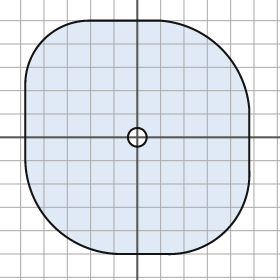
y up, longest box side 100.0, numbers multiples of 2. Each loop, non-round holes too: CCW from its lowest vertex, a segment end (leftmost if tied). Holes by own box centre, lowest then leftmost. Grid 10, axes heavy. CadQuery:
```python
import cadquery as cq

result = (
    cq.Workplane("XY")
    .moveTo(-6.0, -50.0)
    .lineTo(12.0, -50.0)
    .threePointArc((38.0, -40.0), (48.0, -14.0))
    .lineTo(48.0, 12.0)
    .threePointArc((36.0, 38.0), (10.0, 50.0))
    .lineTo(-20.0, 50.0)
    .threePointArc((-40.0, 42.0), (-48.0, 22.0))
    .lineTo(-48.0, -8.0)
    .threePointArc((-36.0, -38.0), (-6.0, -50.0))
    .close()
    .moveTo(0.0, 0.0)
    .circle(4.0)
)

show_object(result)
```